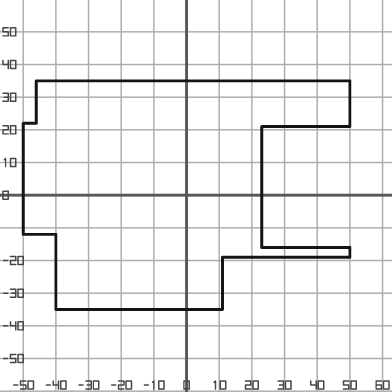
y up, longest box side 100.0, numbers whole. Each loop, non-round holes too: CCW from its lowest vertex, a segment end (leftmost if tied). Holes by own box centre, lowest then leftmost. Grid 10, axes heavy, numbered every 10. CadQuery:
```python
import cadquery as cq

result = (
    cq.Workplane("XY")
    .moveTo(-40.0, -35.0)
    .lineTo(11.0, -35.0)
    .lineTo(11.0, -19.0)
    .lineTo(50.0, -19.0)
    .lineTo(50.0, -16.0)
    .lineTo(23.0, -16.0)
    .lineTo(23.0, 21.0)
    .lineTo(50.0, 21.0)
    .lineTo(50.0, 35.0)
    .lineTo(-46.0, 35.0)
    .lineTo(-46.0, 22.0)
    .lineTo(-50.0, 22.0)
    .lineTo(-50.0, -12.0)
    .lineTo(-40.0, -12.0)
    .close()
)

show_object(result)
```